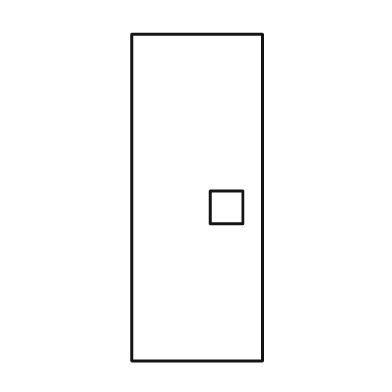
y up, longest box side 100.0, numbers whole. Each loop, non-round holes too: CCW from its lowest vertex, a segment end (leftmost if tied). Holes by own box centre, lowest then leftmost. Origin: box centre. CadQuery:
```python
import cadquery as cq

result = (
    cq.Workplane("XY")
    .moveTo(-20.0, -50.0)
    .lineTo(20.0, -50.0)
    .lineTo(20.0, 50.0)
    .lineTo(-20.0, 50.0)
    .close()
    .moveTo(4.0, -8.0)
    .lineTo(14.0, -8.0)
    .lineTo(14.0, 2.0)
    .lineTo(4.0, 2.0)
    .close()
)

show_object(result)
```